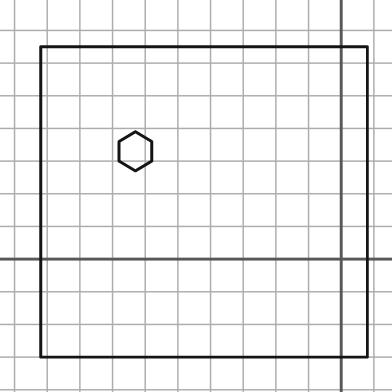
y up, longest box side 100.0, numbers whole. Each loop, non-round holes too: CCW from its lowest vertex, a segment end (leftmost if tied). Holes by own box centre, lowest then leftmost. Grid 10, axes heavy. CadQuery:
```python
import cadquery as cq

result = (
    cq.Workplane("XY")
    .moveTo(-92.0, -30.0)
    .lineTo(8.0, -30.0)
    .lineTo(8.0, 65.0)
    .lineTo(-92.0, 65.0)
    .close()
    .moveTo(-63.0, 27.0)
    .lineTo(-58.0, 30.0)
    .lineTo(-58.0, 36.0)
    .lineTo(-63.0, 39.0)
    .lineTo(-68.0, 36.0)
    .lineTo(-68.0, 30.0)
    .close()
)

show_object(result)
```